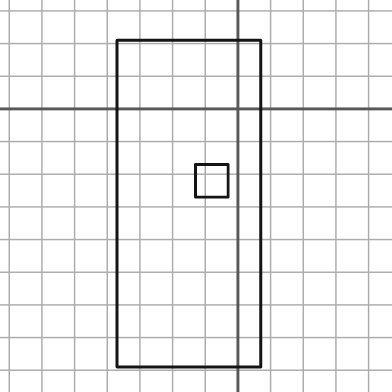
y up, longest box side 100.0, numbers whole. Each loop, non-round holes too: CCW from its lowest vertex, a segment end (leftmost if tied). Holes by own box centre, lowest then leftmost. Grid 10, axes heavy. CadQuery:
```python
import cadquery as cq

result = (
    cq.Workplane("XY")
    .moveTo(-37.0, -79.0)
    .lineTo(7.0, -79.0)
    .lineTo(7.0, 21.0)
    .lineTo(-37.0, 21.0)
    .close()
    .moveTo(-13.0, -27.0)
    .lineTo(-3.0, -27.0)
    .lineTo(-3.0, -17.0)
    .lineTo(-13.0, -17.0)
    .close()
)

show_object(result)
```